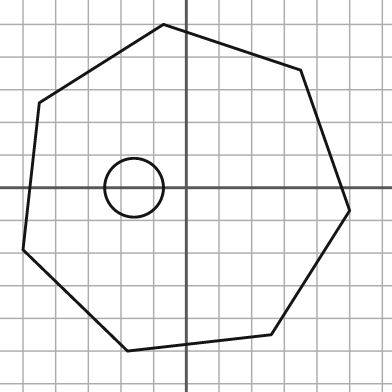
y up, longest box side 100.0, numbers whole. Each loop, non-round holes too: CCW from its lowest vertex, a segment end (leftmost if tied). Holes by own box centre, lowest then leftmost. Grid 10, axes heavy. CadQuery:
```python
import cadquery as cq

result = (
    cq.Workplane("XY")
    .moveTo(-18.0, -50.0)
    .lineTo(26.0, -45.0)
    .lineTo(50.0, -7.0)
    .lineTo(35.0, 36.0)
    .lineTo(-7.0, 50.0)
    .lineTo(-45.0, 26.0)
    .lineTo(-50.0, -19.0)
    .close()
    .moveTo(-16.0, 0.0)
    .circle(9.0)
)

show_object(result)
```